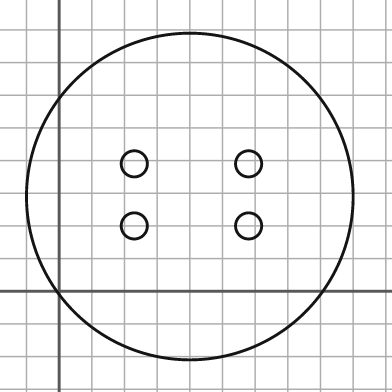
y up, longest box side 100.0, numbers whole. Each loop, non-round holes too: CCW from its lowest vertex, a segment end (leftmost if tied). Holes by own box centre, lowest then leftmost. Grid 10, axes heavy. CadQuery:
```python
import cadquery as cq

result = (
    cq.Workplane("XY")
    .moveTo(40.0, 29.0)
    .circle(50.0)
    .moveTo(23.0, 20.0)
    .circle(4.0)
    .moveTo(58.0, 20.0)
    .circle(4.0)
    .moveTo(23.0, 39.0)
    .circle(4.0)
    .moveTo(58.0, 39.0)
    .circle(4.0)
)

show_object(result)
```